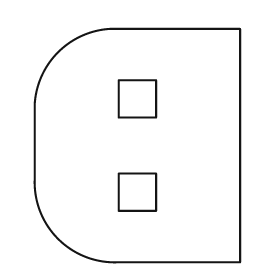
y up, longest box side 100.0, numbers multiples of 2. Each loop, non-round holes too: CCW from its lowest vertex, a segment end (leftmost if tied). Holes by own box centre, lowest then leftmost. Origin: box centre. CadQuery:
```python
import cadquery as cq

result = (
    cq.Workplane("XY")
    .moveTo(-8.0, -50.0)
    .lineTo(44.0, -50.0)
    .lineTo(44.0, 50.0)
    .lineTo(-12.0, 50.0)
    .threePointArc((-34.0, 40.0), (-44.0, 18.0))
    .lineTo(-44.0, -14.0)
    .threePointArc((-34.0, -40.0), (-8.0, -50.0))
    .close()
    .moveTo(-8.0, -28.0)
    .lineTo(8.0, -28.0)
    .lineTo(8.0, -12.0)
    .lineTo(-8.0, -12.0)
    .close()
    .moveTo(-8.0, 12.0)
    .lineTo(8.0, 12.0)
    .lineTo(8.0, 28.0)
    .lineTo(-8.0, 28.0)
    .close()
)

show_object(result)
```